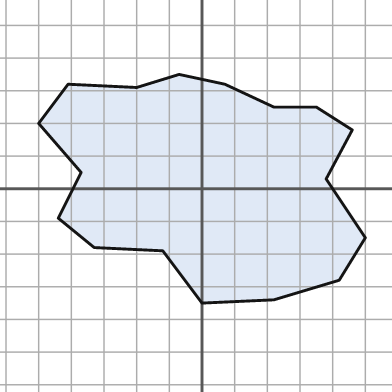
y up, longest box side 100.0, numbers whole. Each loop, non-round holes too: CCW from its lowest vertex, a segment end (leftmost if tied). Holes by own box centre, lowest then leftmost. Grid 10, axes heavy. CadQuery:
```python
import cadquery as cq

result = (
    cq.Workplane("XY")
    .moveTo(0.0, -35.0)
    .lineTo(22.0, -34.0)
    .lineTo(42.0, -28.0)
    .lineTo(50.0, -15.0)
    .lineTo(38.0, 3.0)
    .lineTo(46.0, 18.0)
    .lineTo(35.0, 25.0)
    .lineTo(22.0, 25.0)
    .lineTo(7.0, 32.0)
    .lineTo(-7.0, 35.0)
    .lineTo(-20.0, 31.0)
    .lineTo(-41.0, 32.0)
    .lineTo(-50.0, 20.0)
    .lineTo(-37.0, 5.0)
    .lineTo(-44.0, -9.0)
    .lineTo(-33.0, -18.0)
    .lineTo(-12.0, -19.0)
    .close()
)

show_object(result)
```